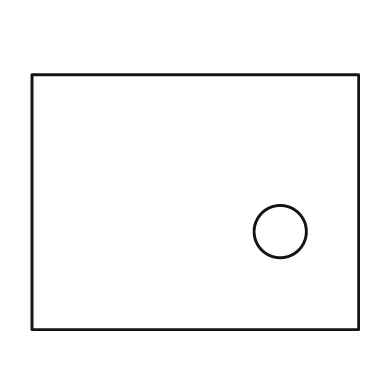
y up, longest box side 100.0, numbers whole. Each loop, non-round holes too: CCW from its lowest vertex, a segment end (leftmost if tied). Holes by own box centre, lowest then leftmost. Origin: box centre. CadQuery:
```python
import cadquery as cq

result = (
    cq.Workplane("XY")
    .moveTo(-50.0, -39.0)
    .lineTo(50.0, -39.0)
    .lineTo(50.0, 39.0)
    .lineTo(-50.0, 39.0)
    .close()
    .moveTo(26.0, -9.0)
    .circle(8.0)
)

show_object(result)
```